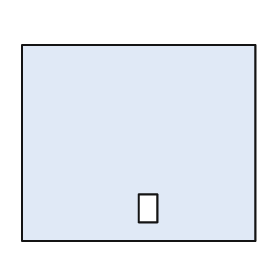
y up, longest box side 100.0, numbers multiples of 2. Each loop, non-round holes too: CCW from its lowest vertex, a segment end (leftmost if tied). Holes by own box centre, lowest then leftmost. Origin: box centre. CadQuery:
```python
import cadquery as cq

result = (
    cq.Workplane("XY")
    .moveTo(-50.0, -42.0)
    .lineTo(50.0, -42.0)
    .lineTo(50.0, 42.0)
    .lineTo(-50.0, 42.0)
    .close()
    .moveTo(0.0, -34.0)
    .lineTo(8.0, -34.0)
    .lineTo(8.0, -22.0)
    .lineTo(0.0, -22.0)
    .close()
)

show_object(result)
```